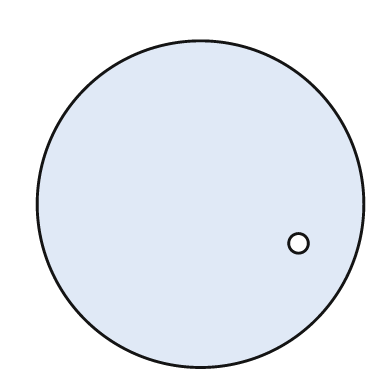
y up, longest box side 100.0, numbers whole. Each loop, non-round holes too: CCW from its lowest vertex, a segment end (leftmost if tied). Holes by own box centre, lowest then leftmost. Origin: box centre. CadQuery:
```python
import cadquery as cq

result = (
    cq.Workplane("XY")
    .moveTo(0.0, 0.0)
    .circle(50.0)
    .moveTo(30.0, -12.0)
    .circle(3.0)
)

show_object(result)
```